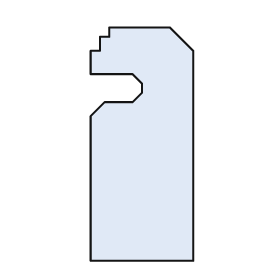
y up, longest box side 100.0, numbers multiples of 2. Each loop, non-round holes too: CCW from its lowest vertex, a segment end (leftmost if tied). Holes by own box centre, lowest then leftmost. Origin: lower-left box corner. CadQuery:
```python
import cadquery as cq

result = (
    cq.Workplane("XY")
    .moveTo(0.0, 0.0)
    .lineTo(44.0, 0.0)
    .lineTo(44.0, 90.0)
    .lineTo(34.0, 100.0)
    .lineTo(8.0, 100.0)
    .lineTo(8.0, 96.0)
    .lineTo(4.0, 96.0)
    .lineTo(4.0, 90.0)
    .lineTo(0.0, 90.0)
    .lineTo(0.0, 80.0)
    .lineTo(18.0, 80.0)
    .lineTo(22.0, 76.0)
    .lineTo(22.0, 72.0)
    .lineTo(18.0, 68.0)
    .lineTo(6.0, 68.0)
    .lineTo(0.0, 62.0)
    .close()
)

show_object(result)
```